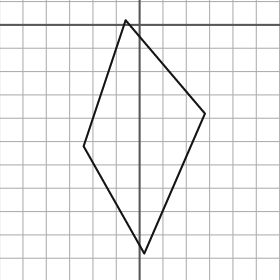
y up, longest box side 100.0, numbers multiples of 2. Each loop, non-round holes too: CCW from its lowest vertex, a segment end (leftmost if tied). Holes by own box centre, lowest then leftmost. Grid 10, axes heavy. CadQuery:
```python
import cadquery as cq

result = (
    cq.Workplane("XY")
    .moveTo(2.0, -98.0)
    .lineTo(28.0, -38.0)
    .lineTo(-6.0, 2.0)
    .lineTo(-24.0, -52.0)
    .close()
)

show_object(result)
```